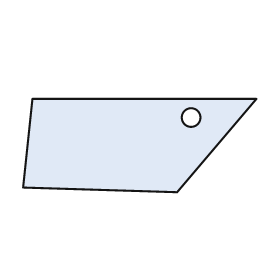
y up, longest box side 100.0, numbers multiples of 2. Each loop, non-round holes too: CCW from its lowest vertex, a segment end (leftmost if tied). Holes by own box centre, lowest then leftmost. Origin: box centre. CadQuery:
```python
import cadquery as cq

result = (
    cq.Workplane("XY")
    .moveTo(16.0, -20.0)
    .lineTo(50.0, 20.0)
    .lineTo(-46.0, 20.0)
    .lineTo(-50.0, -18.0)
    .close()
    .moveTo(22.0, 12.0)
    .circle(4.0)
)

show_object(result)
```